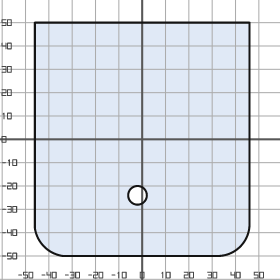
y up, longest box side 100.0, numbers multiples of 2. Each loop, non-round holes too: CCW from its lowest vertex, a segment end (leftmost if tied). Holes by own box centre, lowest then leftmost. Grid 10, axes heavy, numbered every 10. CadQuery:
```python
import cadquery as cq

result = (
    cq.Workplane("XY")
    .moveTo(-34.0, -50.0)
    .lineTo(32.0, -50.0)
    .threePointArc((42.0, -46.0), (46.0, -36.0))
    .lineTo(46.0, 50.0)
    .lineTo(-46.0, 50.0)
    .lineTo(-46.0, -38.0)
    .threePointArc((-42.0, -46.0), (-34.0, -50.0))
    .close()
    .moveTo(-2.0, -24.0)
    .circle(4.0)
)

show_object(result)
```